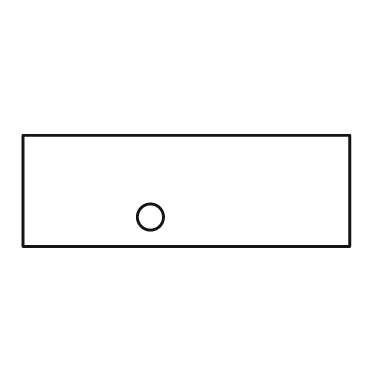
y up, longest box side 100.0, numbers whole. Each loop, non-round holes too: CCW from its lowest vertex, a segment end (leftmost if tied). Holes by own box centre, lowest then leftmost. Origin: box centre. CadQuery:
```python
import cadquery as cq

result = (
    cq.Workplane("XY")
    .moveTo(-50.0, -17.0)
    .lineTo(50.0, -17.0)
    .lineTo(50.0, 17.0)
    .lineTo(-50.0, 17.0)
    .close()
    .moveTo(-11.0, -8.0)
    .circle(4.0)
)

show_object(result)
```